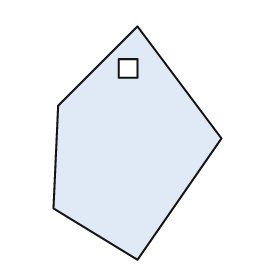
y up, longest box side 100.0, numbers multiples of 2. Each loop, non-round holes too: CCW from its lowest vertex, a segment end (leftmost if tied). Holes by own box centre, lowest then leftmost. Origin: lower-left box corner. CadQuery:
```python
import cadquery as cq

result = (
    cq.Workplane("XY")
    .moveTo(36.0, 0.0)
    .lineTo(72.0, 52.0)
    .lineTo(36.0, 100.0)
    .lineTo(2.0, 66.0)
    .lineTo(0.0, 22.0)
    .close()
    .moveTo(28.0, 78.0)
    .lineTo(36.0, 78.0)
    .lineTo(36.0, 86.0)
    .lineTo(28.0, 86.0)
    .close()
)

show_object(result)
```